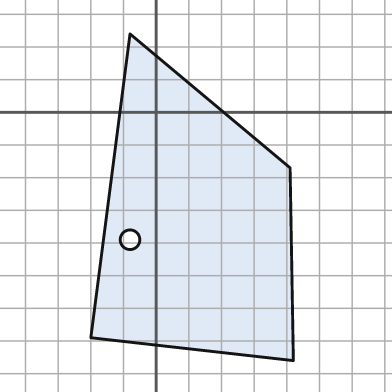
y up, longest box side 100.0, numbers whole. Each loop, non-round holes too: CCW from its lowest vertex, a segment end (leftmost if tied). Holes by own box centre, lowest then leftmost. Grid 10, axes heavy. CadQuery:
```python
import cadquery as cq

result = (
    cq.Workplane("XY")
    .moveTo(42.0, -76.0)
    .lineTo(41.0, -17.0)
    .lineTo(-8.0, 24.0)
    .lineTo(-20.0, -69.0)
    .close()
    .moveTo(-8.0, -39.0)
    .circle(3.0)
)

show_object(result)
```